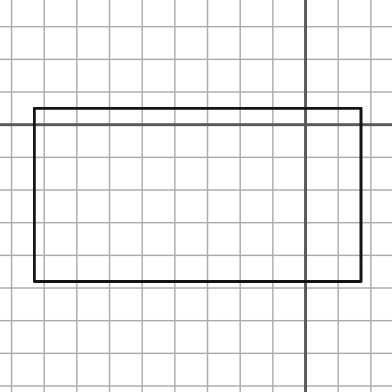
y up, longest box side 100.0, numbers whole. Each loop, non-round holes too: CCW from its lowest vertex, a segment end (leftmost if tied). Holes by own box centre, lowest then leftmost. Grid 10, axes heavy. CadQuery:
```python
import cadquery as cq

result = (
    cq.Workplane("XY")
    .moveTo(-83.0, -48.0)
    .lineTo(17.0, -48.0)
    .lineTo(17.0, 5.0)
    .lineTo(-83.0, 5.0)
    .close()
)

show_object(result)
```